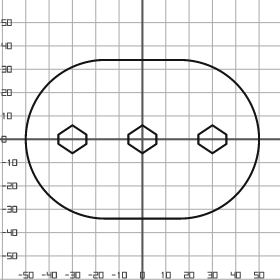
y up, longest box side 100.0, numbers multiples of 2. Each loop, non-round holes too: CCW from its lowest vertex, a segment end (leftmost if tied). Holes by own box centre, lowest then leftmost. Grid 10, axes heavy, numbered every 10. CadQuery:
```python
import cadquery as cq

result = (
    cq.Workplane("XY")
    .moveTo(-16.0, -34.0)
    .lineTo(16.0, -34.0)
    .threePointArc((50.0, 0.0), (16.0, 34.0))
    .lineTo(-16.0, 34.0)
    .threePointArc((-50.0, 0.0), (-16.0, -34.0))
    .close()
    .moveTo(-30.0, -6.0)
    .lineTo(-24.0, -2.0)
    .lineTo(-24.0, 2.0)
    .lineTo(-30.0, 6.0)
    .lineTo(-36.0, 2.0)
    .lineTo(-36.0, -2.0)
    .close()
    .moveTo(0.0, -6.0)
    .lineTo(6.0, -2.0)
    .lineTo(6.0, 2.0)
    .lineTo(0.0, 6.0)
    .lineTo(-6.0, 2.0)
    .lineTo(-6.0, -2.0)
    .close()
    .moveTo(30.0, -6.0)
    .lineTo(36.0, -2.0)
    .lineTo(36.0, 2.0)
    .lineTo(30.0, 6.0)
    .lineTo(24.0, 2.0)
    .lineTo(24.0, -2.0)
    .close()
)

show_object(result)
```